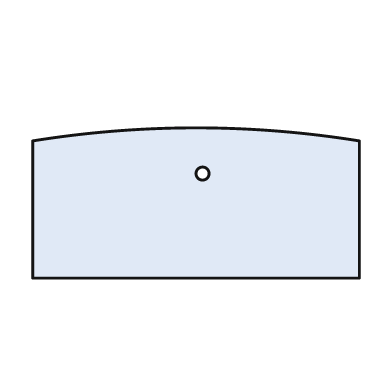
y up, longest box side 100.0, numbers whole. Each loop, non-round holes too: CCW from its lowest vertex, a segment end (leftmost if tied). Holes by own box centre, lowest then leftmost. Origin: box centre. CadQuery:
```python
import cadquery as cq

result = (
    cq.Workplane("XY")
    .moveTo(-50.0, -23.0)
    .lineTo(50.0, -23.0)
    .lineTo(50.0, 19.0)
    .threePointArc((0.0, 23.0), (-50.0, 19.0))
    .close()
    .moveTo(2.0, 9.0)
    .circle(2.0)
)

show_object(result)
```